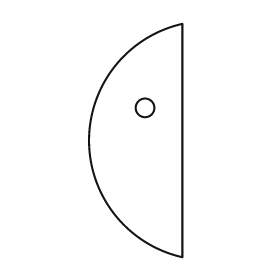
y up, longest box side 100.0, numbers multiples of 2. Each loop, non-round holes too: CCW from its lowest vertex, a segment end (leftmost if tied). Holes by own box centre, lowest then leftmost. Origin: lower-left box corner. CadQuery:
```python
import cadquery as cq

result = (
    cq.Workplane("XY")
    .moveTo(40.0, 0.0)
    .lineTo(40.0, 100.0)
    .threePointArc((0.0, 50.0), (40.0, 0.0))
    .close()
    .moveTo(24.0, 64.0)
    .circle(4.0)
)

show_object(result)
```